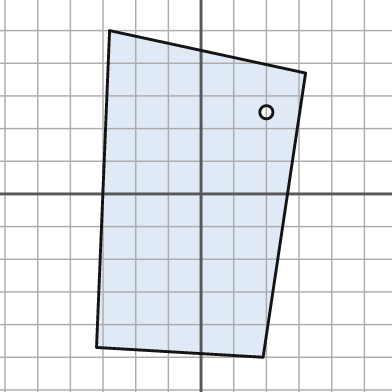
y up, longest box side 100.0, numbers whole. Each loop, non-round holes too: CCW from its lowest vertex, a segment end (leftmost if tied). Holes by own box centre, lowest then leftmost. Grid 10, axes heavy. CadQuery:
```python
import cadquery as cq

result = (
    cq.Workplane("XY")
    .moveTo(19.0, -50.0)
    .lineTo(32.0, 37.0)
    .lineTo(-28.0, 50.0)
    .lineTo(-32.0, -47.0)
    .close()
    .moveTo(20.0, 25.0)
    .circle(2.0)
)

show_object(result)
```